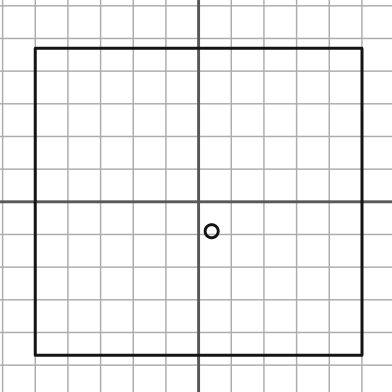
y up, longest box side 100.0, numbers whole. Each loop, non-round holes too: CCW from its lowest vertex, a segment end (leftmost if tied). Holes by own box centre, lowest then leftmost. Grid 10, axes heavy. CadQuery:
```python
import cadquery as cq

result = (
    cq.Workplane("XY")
    .moveTo(-50.0, -47.0)
    .lineTo(50.0, -47.0)
    .lineTo(50.0, 47.0)
    .lineTo(-50.0, 47.0)
    .close()
    .moveTo(4.0, -9.0)
    .circle(2.0)
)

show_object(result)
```